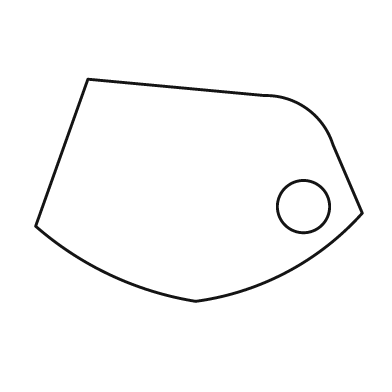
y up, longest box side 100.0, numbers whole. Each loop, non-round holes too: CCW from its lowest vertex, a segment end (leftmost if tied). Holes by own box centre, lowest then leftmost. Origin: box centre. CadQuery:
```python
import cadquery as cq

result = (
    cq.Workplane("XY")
    .moveTo(-1.0, -34.0)
    .threePointArc((27.0, -25.0), (50.0, -7.0))
    .lineTo(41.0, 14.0)
    .threePointArc((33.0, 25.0), (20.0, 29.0))
    .lineTo(-34.0, 34.0)
    .lineTo(-50.0, -11.0)
    .threePointArc((-27.0, -26.0), (-1.0, -34.0))
    .close()
    .moveTo(32.0, -5.0)
    .circle(8.0)
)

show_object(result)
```